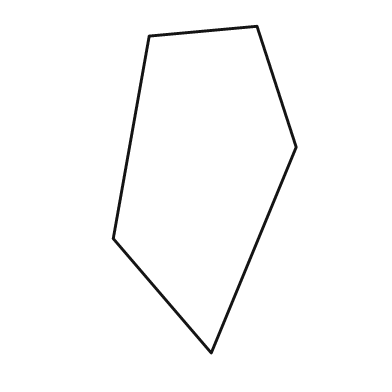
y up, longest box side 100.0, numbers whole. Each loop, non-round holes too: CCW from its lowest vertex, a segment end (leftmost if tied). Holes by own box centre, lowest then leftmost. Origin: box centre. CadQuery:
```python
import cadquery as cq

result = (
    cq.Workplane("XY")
    .moveTo(2.0, -50.0)
    .lineTo(28.0, 13.0)
    .lineTo(16.0, 50.0)
    .lineTo(-17.0, 47.0)
    .lineTo(-28.0, -15.0)
    .close()
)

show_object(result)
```